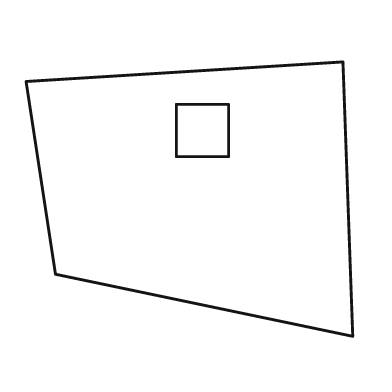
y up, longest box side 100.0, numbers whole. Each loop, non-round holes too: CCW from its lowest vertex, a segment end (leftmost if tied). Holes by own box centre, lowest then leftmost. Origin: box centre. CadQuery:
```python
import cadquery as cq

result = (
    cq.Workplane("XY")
    .moveTo(50.0, -42.0)
    .lineTo(47.0, 42.0)
    .lineTo(-50.0, 36.0)
    .lineTo(-41.0, -23.0)
    .close()
    .moveTo(-4.0, 13.0)
    .lineTo(12.0, 13.0)
    .lineTo(12.0, 29.0)
    .lineTo(-4.0, 29.0)
    .close()
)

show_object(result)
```